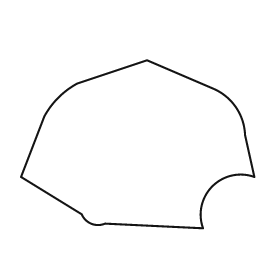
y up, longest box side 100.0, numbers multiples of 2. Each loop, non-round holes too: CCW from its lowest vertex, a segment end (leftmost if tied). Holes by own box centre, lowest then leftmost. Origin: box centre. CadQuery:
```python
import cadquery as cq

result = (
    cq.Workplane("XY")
    .moveTo(28.0, -36.0)
    .threePointArc((32.0, -18.0), (50.0, -14.0))
    .lineTo(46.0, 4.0)
    .threePointArc((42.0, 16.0), (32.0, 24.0))
    .lineTo(4.0, 36.0)
    .lineTo(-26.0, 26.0)
    .threePointArc((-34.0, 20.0), (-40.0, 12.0))
    .lineTo(-50.0, -14.0)
    .lineTo(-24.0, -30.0)
    .threePointArc((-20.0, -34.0), (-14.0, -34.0))
    .close()
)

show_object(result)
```